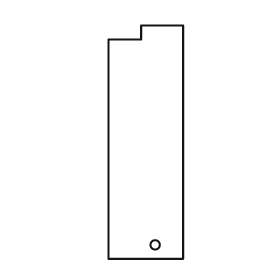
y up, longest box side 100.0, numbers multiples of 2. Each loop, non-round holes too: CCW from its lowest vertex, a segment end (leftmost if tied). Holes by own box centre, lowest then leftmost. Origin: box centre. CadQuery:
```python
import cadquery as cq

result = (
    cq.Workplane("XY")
    .moveTo(-16.0, -50.0)
    .lineTo(16.0, -50.0)
    .lineTo(16.0, 50.0)
    .lineTo(-2.0, 50.0)
    .lineTo(-2.0, 44.0)
    .lineTo(-16.0, 44.0)
    .close()
    .moveTo(4.0, -44.0)
    .circle(2.0)
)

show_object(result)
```